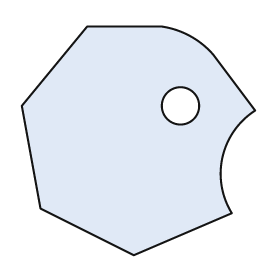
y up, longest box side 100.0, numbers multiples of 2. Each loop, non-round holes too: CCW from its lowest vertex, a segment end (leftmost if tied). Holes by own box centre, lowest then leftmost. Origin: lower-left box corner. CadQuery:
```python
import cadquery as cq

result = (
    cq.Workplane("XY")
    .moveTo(48.0, 0.0)
    .lineTo(90.0, 18.0)
    .threePointArc((86.0, 42.0), (100.0, 62.0))
    .lineTo(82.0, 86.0)
    .threePointArc((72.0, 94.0), (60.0, 98.0))
    .lineTo(28.0, 98.0)
    .lineTo(0.0, 64.0)
    .lineTo(8.0, 20.0)
    .close()
    .moveTo(68.0, 64.0)
    .circle(8.0)
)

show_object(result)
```